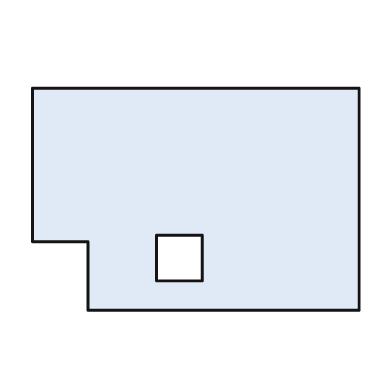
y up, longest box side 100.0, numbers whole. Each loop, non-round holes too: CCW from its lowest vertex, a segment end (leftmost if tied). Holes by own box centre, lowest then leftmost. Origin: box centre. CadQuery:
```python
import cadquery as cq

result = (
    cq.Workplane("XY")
    .moveTo(-33.0, -34.0)
    .lineTo(50.0, -34.0)
    .lineTo(50.0, 34.0)
    .lineTo(-50.0, 34.0)
    .lineTo(-50.0, -13.0)
    .lineTo(-33.0, -13.0)
    .close()
    .moveTo(-12.0, -25.0)
    .lineTo(2.0, -25.0)
    .lineTo(2.0, -11.0)
    .lineTo(-12.0, -11.0)
    .close()
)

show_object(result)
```